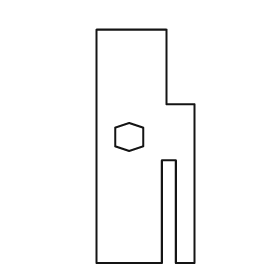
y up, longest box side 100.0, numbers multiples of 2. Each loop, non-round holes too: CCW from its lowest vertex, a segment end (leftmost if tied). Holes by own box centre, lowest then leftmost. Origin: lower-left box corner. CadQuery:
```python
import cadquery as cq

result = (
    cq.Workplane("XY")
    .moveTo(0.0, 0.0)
    .lineTo(28.0, 0.0)
    .lineTo(28.0, 44.0)
    .lineTo(34.0, 44.0)
    .lineTo(34.0, 0.0)
    .lineTo(42.0, 0.0)
    .lineTo(42.0, 68.0)
    .lineTo(30.0, 68.0)
    .lineTo(30.0, 100.0)
    .lineTo(0.0, 100.0)
    .close()
    .moveTo(14.0, 48.0)
    .lineTo(20.0, 50.0)
    .lineTo(20.0, 58.0)
    .lineTo(14.0, 60.0)
    .lineTo(8.0, 58.0)
    .lineTo(8.0, 50.0)
    .close()
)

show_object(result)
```